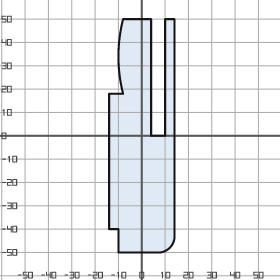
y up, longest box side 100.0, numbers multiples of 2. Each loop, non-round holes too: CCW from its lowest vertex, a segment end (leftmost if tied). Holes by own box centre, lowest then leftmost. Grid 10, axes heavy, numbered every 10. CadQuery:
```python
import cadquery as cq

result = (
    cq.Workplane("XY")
    .moveTo(-10.0, -50.0)
    .lineTo(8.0, -50.0)
    .threePointArc((12.0, -48.0), (14.0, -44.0))
    .lineTo(14.0, 50.0)
    .lineTo(10.0, 50.0)
    .lineTo(10.0, 0.0)
    .lineTo(4.0, 0.0)
    .lineTo(4.0, 50.0)
    .lineTo(-8.0, 50.0)
    .threePointArc((-10.0, 34.0), (-8.0, 18.0))
    .lineTo(-14.0, 18.0)
    .lineTo(-14.0, -40.0)
    .lineTo(-10.0, -40.0)
    .close()
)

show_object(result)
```